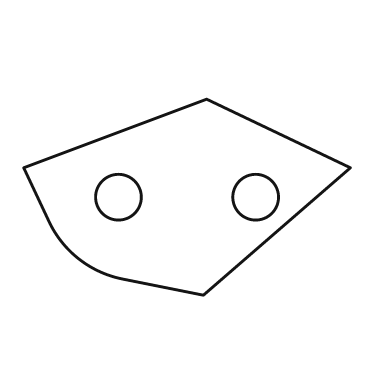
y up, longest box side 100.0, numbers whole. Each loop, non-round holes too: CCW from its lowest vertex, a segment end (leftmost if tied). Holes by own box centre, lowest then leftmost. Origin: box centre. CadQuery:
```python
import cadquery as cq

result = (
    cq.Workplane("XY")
    .moveTo(5.0, -30.0)
    .lineTo(50.0, 9.0)
    .lineTo(6.0, 30.0)
    .lineTo(-50.0, 9.0)
    .lineTo(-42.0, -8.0)
    .threePointArc((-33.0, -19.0), (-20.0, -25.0))
    .close()
    .moveTo(-21.0, 0.0)
    .circle(7.0)
    .moveTo(21.0, 0.0)
    .circle(7.0)
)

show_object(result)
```